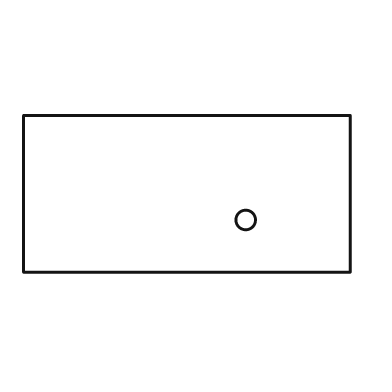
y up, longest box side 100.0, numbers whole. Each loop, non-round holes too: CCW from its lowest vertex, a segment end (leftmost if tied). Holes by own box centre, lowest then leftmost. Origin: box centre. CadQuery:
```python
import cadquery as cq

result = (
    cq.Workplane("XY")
    .moveTo(-50.0, -24.0)
    .lineTo(50.0, -24.0)
    .lineTo(50.0, 24.0)
    .lineTo(-50.0, 24.0)
    .close()
    .moveTo(18.0, -8.0)
    .circle(3.0)
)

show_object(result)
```